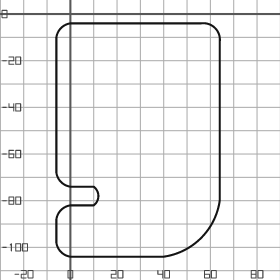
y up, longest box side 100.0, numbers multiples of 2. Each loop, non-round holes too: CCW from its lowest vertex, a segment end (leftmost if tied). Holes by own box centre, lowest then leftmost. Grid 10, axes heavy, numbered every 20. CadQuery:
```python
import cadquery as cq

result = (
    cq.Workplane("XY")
    .moveTo(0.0, -104.0)
    .lineTo(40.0, -104.0)
    .threePointArc((56.0, -96.0), (64.0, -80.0))
    .lineTo(64.0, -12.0)
    .threePointArc((62.0, -6.0), (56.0, -4.0))
    .lineTo(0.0, -4.0)
    .threePointArc((-4.0, -6.0), (-6.0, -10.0))
    .lineTo(-6.0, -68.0)
    .threePointArc((-4.0, -72.0), (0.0, -74.0))
    .lineTo(10.0, -74.0)
    .threePointArc((12.0, -78.0), (10.0, -82.0))
    .lineTo(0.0, -82.0)
    .threePointArc((-4.0, -84.0), (-6.0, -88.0))
    .lineTo(-6.0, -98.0)
    .threePointArc((-4.0, -102.0), (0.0, -104.0))
    .close()
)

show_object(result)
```